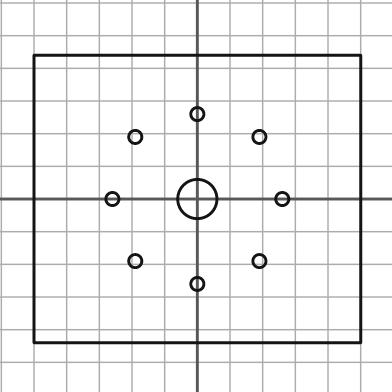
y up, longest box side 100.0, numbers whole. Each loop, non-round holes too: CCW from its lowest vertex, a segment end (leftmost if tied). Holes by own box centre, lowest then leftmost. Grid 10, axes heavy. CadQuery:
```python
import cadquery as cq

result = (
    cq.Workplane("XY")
    .moveTo(-50.0, -44.0)
    .lineTo(50.0, -44.0)
    .lineTo(50.0, 44.0)
    .lineTo(-50.0, 44.0)
    .close()
    .moveTo(0.0, -26.0)
    .circle(2.0)
    .moveTo(-19.0, -19.0)
    .circle(2.0)
    .moveTo(19.0, -19.0)
    .circle(2.0)
    .moveTo(-26.0, 0.0)
    .circle(2.0)
    .moveTo(0.0, 0.0)
    .circle(6.0)
    .moveTo(26.0, 0.0)
    .circle(2.0)
    .moveTo(-19.0, 19.0)
    .circle(2.0)
    .moveTo(19.0, 19.0)
    .circle(2.0)
    .moveTo(0.0, 26.0)
    .circle(2.0)
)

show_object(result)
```